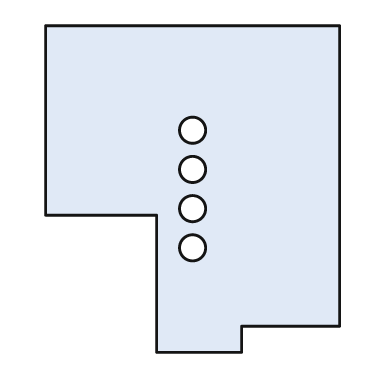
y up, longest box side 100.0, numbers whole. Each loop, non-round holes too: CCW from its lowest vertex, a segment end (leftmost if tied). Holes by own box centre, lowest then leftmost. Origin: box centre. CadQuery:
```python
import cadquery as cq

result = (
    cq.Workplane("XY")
    .moveTo(-11.0, -50.0)
    .lineTo(15.0, -50.0)
    .lineTo(15.0, -42.0)
    .lineTo(45.0, -42.0)
    .lineTo(45.0, 50.0)
    .lineTo(-45.0, 50.0)
    .lineTo(-45.0, -8.0)
    .lineTo(-11.0, -8.0)
    .close()
    .moveTo(0.0, -18.0)
    .circle(4.0)
    .moveTo(0.0, -6.0)
    .circle(4.0)
    .moveTo(0.0, 6.0)
    .circle(4.0)
    .moveTo(0.0, 18.0)
    .circle(4.0)
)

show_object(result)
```